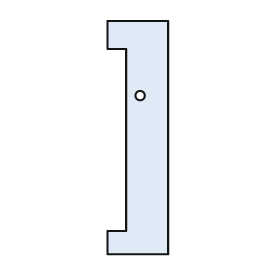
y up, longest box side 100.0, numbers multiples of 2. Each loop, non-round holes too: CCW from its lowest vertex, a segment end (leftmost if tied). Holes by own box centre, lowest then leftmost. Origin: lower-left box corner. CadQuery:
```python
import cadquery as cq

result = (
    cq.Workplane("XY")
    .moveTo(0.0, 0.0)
    .lineTo(26.0, 0.0)
    .lineTo(26.0, 100.0)
    .lineTo(0.0, 100.0)
    .lineTo(0.0, 88.0)
    .lineTo(8.0, 88.0)
    .lineTo(8.0, 10.0)
    .lineTo(0.0, 10.0)
    .close()
    .moveTo(14.0, 68.0)
    .circle(2.0)
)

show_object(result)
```